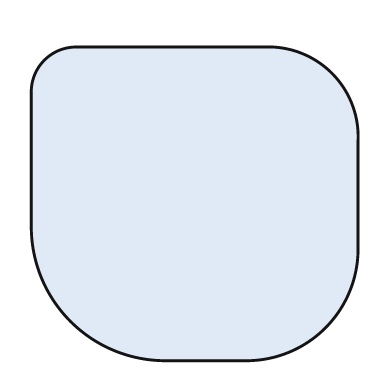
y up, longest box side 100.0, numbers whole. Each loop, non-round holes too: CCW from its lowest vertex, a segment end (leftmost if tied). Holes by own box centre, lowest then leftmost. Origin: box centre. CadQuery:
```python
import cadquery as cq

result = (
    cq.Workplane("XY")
    .moveTo(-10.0, -48.0)
    .lineTo(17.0, -48.0)
    .threePointArc((40.0, -38.0), (50.0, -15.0))
    .lineTo(50.0, 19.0)
    .threePointArc((42.0, 40.0), (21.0, 48.0))
    .lineTo(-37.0, 48.0)
    .threePointArc((-46.0, 44.0), (-50.0, 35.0))
    .lineTo(-50.0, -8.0)
    .threePointArc((-38.0, -36.0), (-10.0, -48.0))
    .close()
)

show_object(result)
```